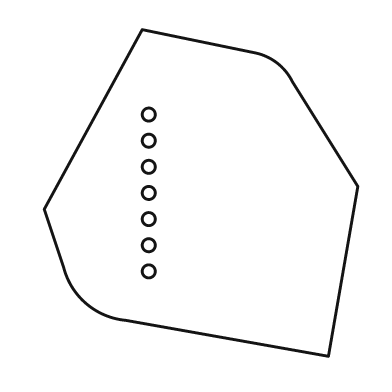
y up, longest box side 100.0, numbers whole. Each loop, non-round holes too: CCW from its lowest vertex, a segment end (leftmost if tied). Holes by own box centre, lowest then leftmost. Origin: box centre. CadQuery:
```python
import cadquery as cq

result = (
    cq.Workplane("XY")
    .moveTo(39.0, -50.0)
    .lineTo(48.0, 2.0)
    .lineTo(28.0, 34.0)
    .threePointArc((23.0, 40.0), (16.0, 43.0))
    .lineTo(-18.0, 50.0)
    .lineTo(-48.0, -5.0)
    .lineTo(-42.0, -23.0)
    .threePointArc((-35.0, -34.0), (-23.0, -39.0))
    .close()
    .moveTo(-16.0, -24.0)
    .circle(2.0)
    .moveTo(-16.0, -16.0)
    .circle(2.0)
    .moveTo(-16.0, -8.0)
    .circle(2.0)
    .moveTo(-16.0, 0.0)
    .circle(2.0)
    .moveTo(-16.0, 8.0)
    .circle(2.0)
    .moveTo(-16.0, 16.0)
    .circle(2.0)
    .moveTo(-16.0, 24.0)
    .circle(2.0)
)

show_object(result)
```